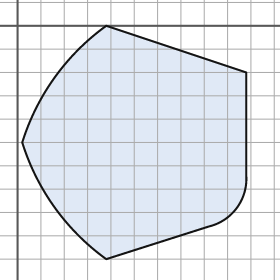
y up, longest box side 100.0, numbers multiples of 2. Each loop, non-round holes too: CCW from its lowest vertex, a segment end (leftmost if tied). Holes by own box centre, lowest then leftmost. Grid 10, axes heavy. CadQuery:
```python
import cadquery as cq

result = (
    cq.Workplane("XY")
    .moveTo(38.0, -100.0)
    .lineTo(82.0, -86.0)
    .threePointArc((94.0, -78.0), (98.0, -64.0))
    .lineTo(98.0, -20.0)
    .lineTo(38.0, 0.0)
    .threePointArc((16.0, -22.0), (2.0, -50.0))
    .threePointArc((16.0, -78.0), (38.0, -100.0))
    .close()
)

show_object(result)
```